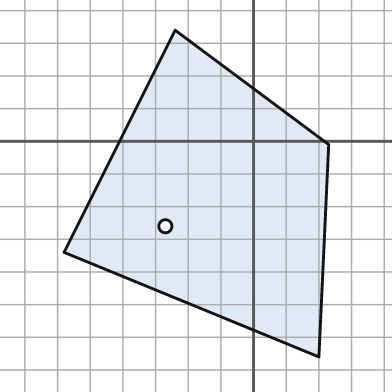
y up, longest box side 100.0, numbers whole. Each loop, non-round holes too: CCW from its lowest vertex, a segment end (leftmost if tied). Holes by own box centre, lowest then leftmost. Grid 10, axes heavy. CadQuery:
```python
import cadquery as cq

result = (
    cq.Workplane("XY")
    .moveTo(20.0, -66.0)
    .lineTo(23.0, -1.0)
    .lineTo(-24.0, 34.0)
    .lineTo(-58.0, -34.0)
    .close()
    .moveTo(-27.0, -26.0)
    .circle(2.0)
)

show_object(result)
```